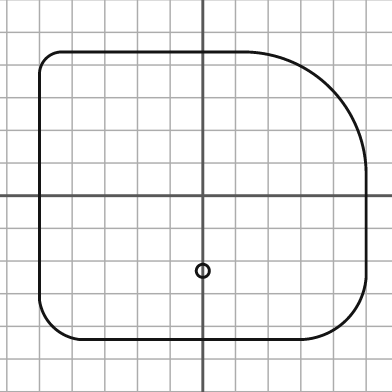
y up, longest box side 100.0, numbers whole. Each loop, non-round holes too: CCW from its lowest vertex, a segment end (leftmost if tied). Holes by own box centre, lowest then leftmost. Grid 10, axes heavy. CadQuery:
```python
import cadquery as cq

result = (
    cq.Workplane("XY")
    .moveTo(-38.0, -44.0)
    .lineTo(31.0, -44.0)
    .threePointArc((44.0, -38.0), (50.0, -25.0))
    .lineTo(50.0, 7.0)
    .threePointArc((39.0, 33.0), (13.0, 44.0))
    .lineTo(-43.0, 44.0)
    .threePointArc((-48.0, 42.0), (-50.0, 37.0))
    .lineTo(-50.0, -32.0)
    .threePointArc((-46.0, -40.0), (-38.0, -44.0))
    .close()
    .moveTo(0.0, -23.0)
    .circle(2.0)
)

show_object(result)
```